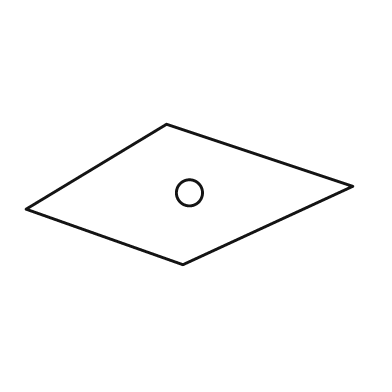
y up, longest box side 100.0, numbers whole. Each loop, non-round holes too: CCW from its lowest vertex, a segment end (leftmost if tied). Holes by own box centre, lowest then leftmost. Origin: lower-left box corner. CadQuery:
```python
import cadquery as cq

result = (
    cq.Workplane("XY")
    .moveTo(48.0, 0.0)
    .lineTo(100.0, 24.0)
    .lineTo(43.0, 43.0)
    .lineTo(0.0, 17.0)
    .close()
    .moveTo(50.0, 22.0)
    .circle(4.0)
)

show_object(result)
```